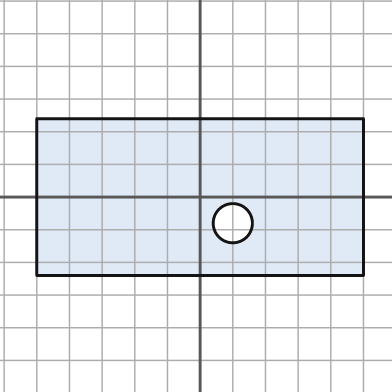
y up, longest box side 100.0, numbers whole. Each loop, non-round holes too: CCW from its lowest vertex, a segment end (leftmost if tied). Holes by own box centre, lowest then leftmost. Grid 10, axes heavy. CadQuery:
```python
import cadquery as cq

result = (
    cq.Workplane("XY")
    .moveTo(-50.0, -24.0)
    .lineTo(50.0, -24.0)
    .lineTo(50.0, 24.0)
    .lineTo(-50.0, 24.0)
    .close()
    .moveTo(10.0, -8.0)
    .circle(6.0)
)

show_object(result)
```